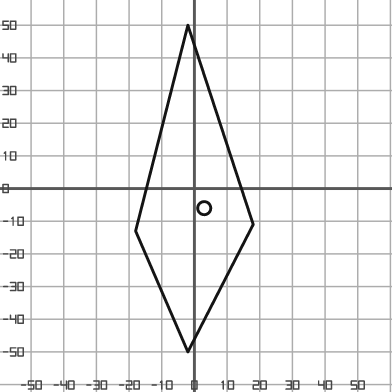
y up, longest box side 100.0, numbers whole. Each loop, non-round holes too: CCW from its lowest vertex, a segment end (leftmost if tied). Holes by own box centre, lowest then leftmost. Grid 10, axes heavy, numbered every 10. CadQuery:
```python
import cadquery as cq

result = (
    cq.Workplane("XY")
    .moveTo(-2.0, -50.0)
    .lineTo(18.0, -11.0)
    .lineTo(-2.0, 50.0)
    .lineTo(-18.0, -13.0)
    .close()
    .moveTo(3.0, -6.0)
    .circle(2.0)
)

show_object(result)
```